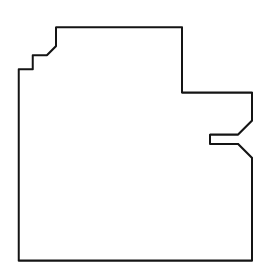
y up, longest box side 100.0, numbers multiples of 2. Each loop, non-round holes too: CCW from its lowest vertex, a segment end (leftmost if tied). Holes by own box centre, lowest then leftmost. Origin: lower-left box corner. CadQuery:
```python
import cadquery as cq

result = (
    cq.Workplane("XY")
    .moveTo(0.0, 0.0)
    .lineTo(100.0, 0.0)
    .lineTo(100.0, 44.0)
    .lineTo(94.0, 50.0)
    .lineTo(82.0, 50.0)
    .lineTo(82.0, 54.0)
    .lineTo(94.0, 54.0)
    .lineTo(100.0, 60.0)
    .lineTo(100.0, 72.0)
    .lineTo(70.0, 72.0)
    .lineTo(70.0, 100.0)
    .lineTo(16.0, 100.0)
    .lineTo(16.0, 92.0)
    .lineTo(12.0, 88.0)
    .lineTo(6.0, 88.0)
    .lineTo(6.0, 82.0)
    .lineTo(0.0, 82.0)
    .close()
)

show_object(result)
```